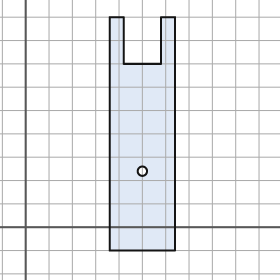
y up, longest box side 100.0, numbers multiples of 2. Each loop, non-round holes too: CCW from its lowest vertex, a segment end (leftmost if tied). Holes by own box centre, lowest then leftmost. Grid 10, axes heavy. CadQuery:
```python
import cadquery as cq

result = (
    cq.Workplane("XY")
    .moveTo(36.0, -10.0)
    .lineTo(64.0, -10.0)
    .lineTo(64.0, 90.0)
    .lineTo(58.0, 90.0)
    .lineTo(58.0, 70.0)
    .lineTo(42.0, 70.0)
    .lineTo(42.0, 90.0)
    .lineTo(36.0, 90.0)
    .close()
    .moveTo(50.0, 24.0)
    .circle(2.0)
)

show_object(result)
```